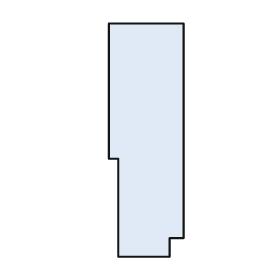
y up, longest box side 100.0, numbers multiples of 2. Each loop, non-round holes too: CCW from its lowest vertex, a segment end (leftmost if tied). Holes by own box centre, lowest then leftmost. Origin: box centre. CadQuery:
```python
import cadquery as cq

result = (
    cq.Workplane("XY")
    .moveTo(-12.0, -50.0)
    .lineTo(10.0, -50.0)
    .lineTo(10.0, -42.0)
    .lineTo(16.0, -42.0)
    .lineTo(16.0, 50.0)
    .lineTo(-16.0, 50.0)
    .lineTo(-16.0, -8.0)
    .lineTo(-12.0, -8.0)
    .close()
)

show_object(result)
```